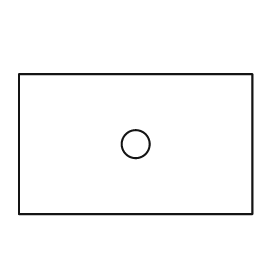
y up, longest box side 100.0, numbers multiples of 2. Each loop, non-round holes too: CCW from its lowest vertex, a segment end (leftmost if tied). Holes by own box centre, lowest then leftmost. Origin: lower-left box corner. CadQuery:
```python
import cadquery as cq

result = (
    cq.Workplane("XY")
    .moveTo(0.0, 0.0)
    .lineTo(100.0, 0.0)
    .lineTo(100.0, 60.0)
    .lineTo(0.0, 60.0)
    .close()
    .moveTo(50.0, 30.0)
    .circle(6.0)
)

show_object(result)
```